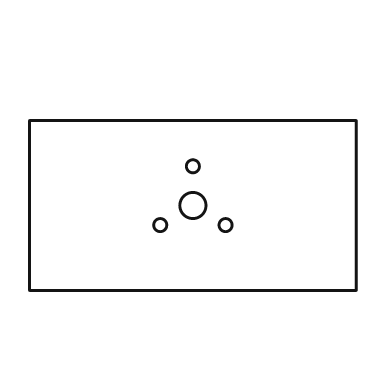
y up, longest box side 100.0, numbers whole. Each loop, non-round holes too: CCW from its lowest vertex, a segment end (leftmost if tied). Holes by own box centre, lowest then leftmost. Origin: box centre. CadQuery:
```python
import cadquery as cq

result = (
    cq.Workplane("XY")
    .moveTo(-50.0, -26.0)
    .lineTo(50.0, -26.0)
    .lineTo(50.0, 26.0)
    .lineTo(-50.0, 26.0)
    .close()
    .moveTo(-10.0, -6.0)
    .circle(2.0)
    .moveTo(10.0, -6.0)
    .circle(2.0)
    .moveTo(0.0, 0.0)
    .circle(4.0)
    .moveTo(0.0, 12.0)
    .circle(2.0)
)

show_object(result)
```